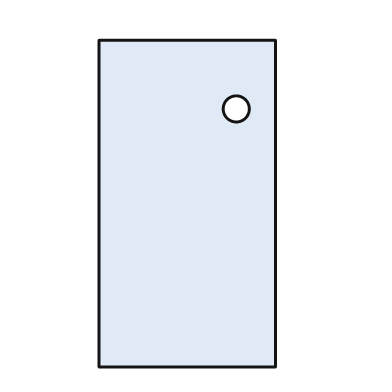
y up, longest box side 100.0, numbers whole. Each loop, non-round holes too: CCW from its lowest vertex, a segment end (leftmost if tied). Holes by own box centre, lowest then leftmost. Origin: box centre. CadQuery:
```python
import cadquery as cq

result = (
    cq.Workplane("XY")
    .moveTo(-27.0, -50.0)
    .lineTo(27.0, -50.0)
    .lineTo(27.0, 50.0)
    .lineTo(-27.0, 50.0)
    .close()
    .moveTo(15.0, 29.0)
    .circle(4.0)
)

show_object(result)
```